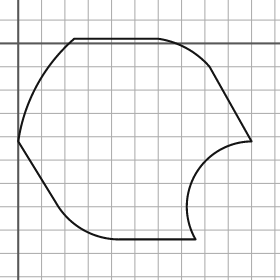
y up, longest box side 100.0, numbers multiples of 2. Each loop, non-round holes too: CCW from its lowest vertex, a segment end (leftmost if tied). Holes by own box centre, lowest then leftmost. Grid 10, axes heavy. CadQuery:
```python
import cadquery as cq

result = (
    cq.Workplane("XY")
    .moveTo(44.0, -84.0)
    .lineTo(76.0, -84.0)
    .threePointArc((76.0, -56.0), (100.0, -42.0))
    .lineTo(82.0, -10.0)
    .threePointArc((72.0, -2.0), (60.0, 2.0))
    .lineTo(24.0, 2.0)
    .threePointArc((8.0, -18.0), (0.0, -42.0))
    .lineTo(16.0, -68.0)
    .threePointArc((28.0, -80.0), (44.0, -84.0))
    .close()
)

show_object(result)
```